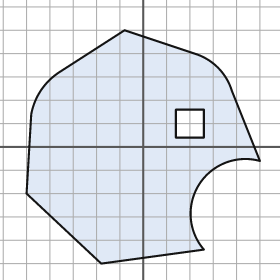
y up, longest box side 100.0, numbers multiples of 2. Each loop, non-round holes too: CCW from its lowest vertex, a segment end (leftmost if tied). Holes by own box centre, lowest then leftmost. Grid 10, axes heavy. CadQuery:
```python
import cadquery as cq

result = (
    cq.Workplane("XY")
    .moveTo(-18.0, -50.0)
    .lineTo(26.0, -44.0)
    .threePointArc((24.0, -16.0), (50.0, -6.0))
    .lineTo(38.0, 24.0)
    .threePointArc((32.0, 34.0), (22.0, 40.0))
    .lineTo(-8.0, 50.0)
    .lineTo(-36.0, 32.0)
    .threePointArc((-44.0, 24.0), (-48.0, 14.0))
    .lineTo(-50.0, -20.0)
    .close()
    .moveTo(14.0, 4.0)
    .lineTo(26.0, 4.0)
    .lineTo(26.0, 16.0)
    .lineTo(14.0, 16.0)
    .close()
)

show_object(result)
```